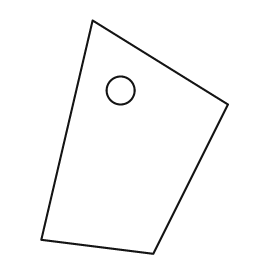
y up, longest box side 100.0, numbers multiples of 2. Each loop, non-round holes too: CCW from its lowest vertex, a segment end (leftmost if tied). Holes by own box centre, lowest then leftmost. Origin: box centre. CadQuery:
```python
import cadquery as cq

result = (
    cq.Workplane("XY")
    .moveTo(8.0, -50.0)
    .lineTo(40.0, 14.0)
    .lineTo(-18.0, 50.0)
    .lineTo(-40.0, -44.0)
    .close()
    .moveTo(-6.0, 20.0)
    .circle(6.0)
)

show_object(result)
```